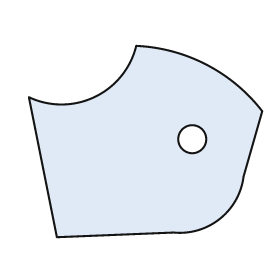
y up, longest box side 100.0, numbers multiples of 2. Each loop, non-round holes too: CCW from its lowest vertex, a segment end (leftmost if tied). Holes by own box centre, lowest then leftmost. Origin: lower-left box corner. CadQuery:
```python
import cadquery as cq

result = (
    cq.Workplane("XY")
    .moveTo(12.0, 0.0)
    .lineTo(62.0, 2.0)
    .threePointArc((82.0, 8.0), (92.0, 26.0))
    .lineTo(100.0, 54.0)
    .threePointArc((76.0, 74.0), (46.0, 82.0))
    .threePointArc((28.0, 60.0), (0.0, 60.0))
    .close()
    .moveTo(70.0, 42.0)
    .circle(6.0)
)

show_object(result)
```